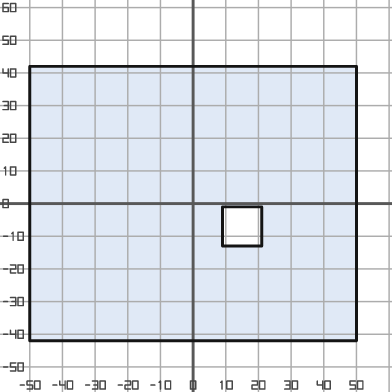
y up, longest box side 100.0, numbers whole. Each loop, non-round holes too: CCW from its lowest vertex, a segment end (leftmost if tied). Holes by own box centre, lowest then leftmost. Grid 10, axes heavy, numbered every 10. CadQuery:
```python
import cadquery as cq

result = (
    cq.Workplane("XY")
    .moveTo(-50.0, -42.0)
    .lineTo(50.0, -42.0)
    .lineTo(50.0, 42.0)
    .lineTo(-50.0, 42.0)
    .close()
    .moveTo(9.0, -13.0)
    .lineTo(21.0, -13.0)
    .lineTo(21.0, -1.0)
    .lineTo(9.0, -1.0)
    .close()
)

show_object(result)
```